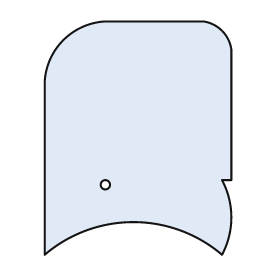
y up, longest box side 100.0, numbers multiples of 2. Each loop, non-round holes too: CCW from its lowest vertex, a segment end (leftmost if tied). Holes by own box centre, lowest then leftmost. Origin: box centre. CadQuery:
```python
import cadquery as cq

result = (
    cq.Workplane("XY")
    .moveTo(-40.0, -50.0)
    .threePointArc((-2.0, -36.0), (36.0, -50.0))
    .threePointArc((40.0, -34.0), (36.0, -18.0))
    .lineTo(40.0, -18.0)
    .lineTo(40.0, 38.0)
    .threePointArc((36.0, 46.0), (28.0, 50.0))
    .lineTo(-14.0, 50.0)
    .threePointArc((-32.0, 42.0), (-40.0, 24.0))
    .close()
    .moveTo(-14.0, -20.0)
    .circle(2.0)
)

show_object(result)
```